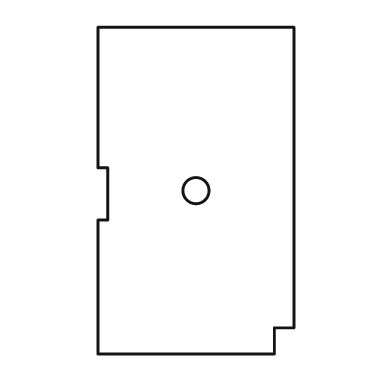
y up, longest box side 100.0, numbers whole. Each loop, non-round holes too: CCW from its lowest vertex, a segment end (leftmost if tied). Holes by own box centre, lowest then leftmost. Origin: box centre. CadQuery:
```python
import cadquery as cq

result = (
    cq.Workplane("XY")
    .moveTo(-30.0, -50.0)
    .lineTo(24.0, -50.0)
    .lineTo(24.0, -42.0)
    .lineTo(30.0, -42.0)
    .lineTo(30.0, 50.0)
    .lineTo(-30.0, 50.0)
    .lineTo(-30.0, 7.0)
    .lineTo(-27.0, 7.0)
    .lineTo(-27.0, -9.0)
    .lineTo(-30.0, -9.0)
    .close()
    .moveTo(0.0, 0.0)
    .circle(4.0)
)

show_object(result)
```